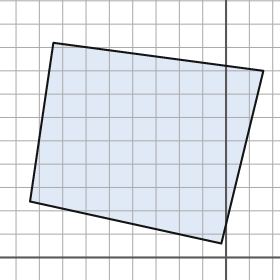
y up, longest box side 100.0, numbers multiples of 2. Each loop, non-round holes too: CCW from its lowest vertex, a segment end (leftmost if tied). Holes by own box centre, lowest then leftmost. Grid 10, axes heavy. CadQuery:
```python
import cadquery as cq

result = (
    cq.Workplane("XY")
    .moveTo(-2.0, 6.0)
    .lineTo(16.0, 80.0)
    .lineTo(-74.0, 92.0)
    .lineTo(-84.0, 24.0)
    .close()
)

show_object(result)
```